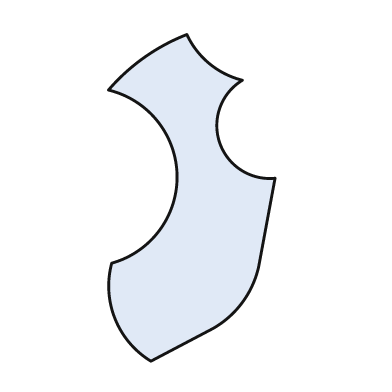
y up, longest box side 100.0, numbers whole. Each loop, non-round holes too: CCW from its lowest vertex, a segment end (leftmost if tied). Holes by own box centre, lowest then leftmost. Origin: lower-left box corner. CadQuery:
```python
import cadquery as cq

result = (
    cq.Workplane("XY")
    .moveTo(13.0, 0.0)
    .lineTo(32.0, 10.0)
    .threePointArc((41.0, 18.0), (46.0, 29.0))
    .lineTo(51.0, 56.0)
    .threePointArc((34.0, 67.0), (41.0, 86.0))
    .threePointArc((31.0, 91.0), (24.0, 100.0))
    .threePointArc((11.0, 93.0), (0.0, 83.0))
    .threePointArc((21.0, 57.0), (1.0, 30.0))
    .threePointArc((2.0, 13.0), (13.0, 0.0))
    .close()
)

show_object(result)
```